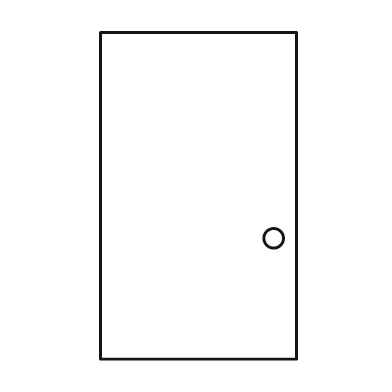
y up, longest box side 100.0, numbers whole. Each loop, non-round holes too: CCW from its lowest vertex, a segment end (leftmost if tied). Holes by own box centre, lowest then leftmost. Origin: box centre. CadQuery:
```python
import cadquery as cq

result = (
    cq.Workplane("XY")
    .moveTo(-30.0, -50.0)
    .lineTo(30.0, -50.0)
    .lineTo(30.0, 50.0)
    .lineTo(-30.0, 50.0)
    .close()
    .moveTo(23.0, -13.0)
    .circle(3.0)
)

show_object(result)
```